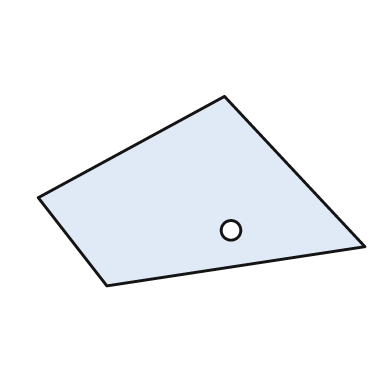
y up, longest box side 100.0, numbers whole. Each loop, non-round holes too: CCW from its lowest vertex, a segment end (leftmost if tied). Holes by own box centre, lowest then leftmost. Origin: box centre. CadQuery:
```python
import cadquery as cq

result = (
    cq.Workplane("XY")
    .moveTo(-29.0, -29.0)
    .lineTo(50.0, -17.0)
    .lineTo(7.0, 29.0)
    .lineTo(-50.0, -2.0)
    .close()
    .moveTo(9.0, -12.0)
    .circle(3.0)
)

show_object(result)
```